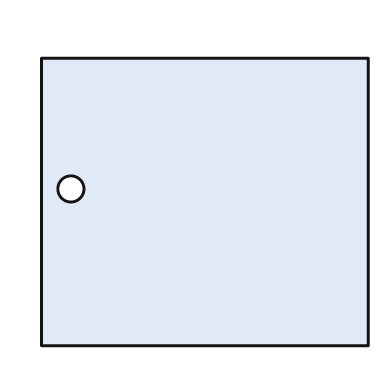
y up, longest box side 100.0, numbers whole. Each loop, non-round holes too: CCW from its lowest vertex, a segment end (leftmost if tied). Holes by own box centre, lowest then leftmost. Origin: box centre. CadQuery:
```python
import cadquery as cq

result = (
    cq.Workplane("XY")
    .moveTo(-50.0, -44.0)
    .lineTo(50.0, -44.0)
    .lineTo(50.0, 44.0)
    .lineTo(-50.0, 44.0)
    .close()
    .moveTo(-41.0, 4.0)
    .circle(4.0)
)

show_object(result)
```